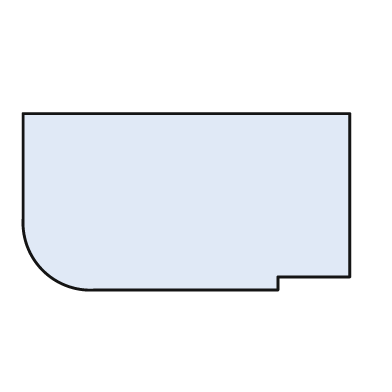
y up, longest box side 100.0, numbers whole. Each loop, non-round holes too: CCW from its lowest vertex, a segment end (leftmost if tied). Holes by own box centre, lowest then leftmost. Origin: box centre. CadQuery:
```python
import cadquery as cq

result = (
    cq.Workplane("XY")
    .moveTo(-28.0, -27.0)
    .lineTo(28.0, -27.0)
    .lineTo(28.0, -23.0)
    .lineTo(50.0, -23.0)
    .lineTo(50.0, 27.0)
    .lineTo(-50.0, 27.0)
    .lineTo(-50.0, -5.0)
    .threePointArc((-44.0, -21.0), (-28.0, -27.0))
    .close()
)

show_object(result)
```